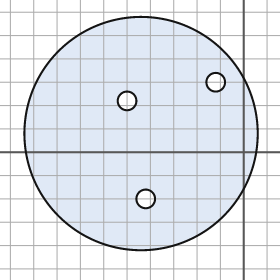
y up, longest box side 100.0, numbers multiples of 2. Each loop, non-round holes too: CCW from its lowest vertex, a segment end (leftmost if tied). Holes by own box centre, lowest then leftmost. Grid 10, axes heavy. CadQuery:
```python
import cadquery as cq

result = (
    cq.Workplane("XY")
    .moveTo(-44.0, 8.0)
    .circle(50.0)
    .moveTo(-42.0, -20.0)
    .circle(4.0)
    .moveTo(-50.0, 22.0)
    .circle(4.0)
    .moveTo(-12.0, 30.0)
    .circle(4.0)
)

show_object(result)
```